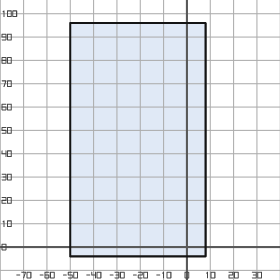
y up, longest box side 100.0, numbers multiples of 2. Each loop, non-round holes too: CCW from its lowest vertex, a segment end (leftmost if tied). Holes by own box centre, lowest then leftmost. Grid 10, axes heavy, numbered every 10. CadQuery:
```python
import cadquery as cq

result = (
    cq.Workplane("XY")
    .moveTo(-50.0, -4.0)
    .lineTo(8.0, -4.0)
    .lineTo(8.0, 96.0)
    .lineTo(-50.0, 96.0)
    .close()
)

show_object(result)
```